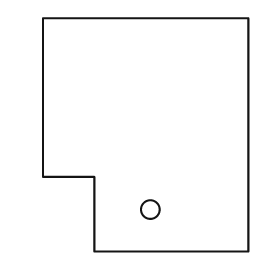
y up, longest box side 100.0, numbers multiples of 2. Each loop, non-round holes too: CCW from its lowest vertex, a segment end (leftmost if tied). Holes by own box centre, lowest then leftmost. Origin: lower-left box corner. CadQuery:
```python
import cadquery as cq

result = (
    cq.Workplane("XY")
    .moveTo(22.0, 0.0)
    .lineTo(88.0, 0.0)
    .lineTo(88.0, 100.0)
    .lineTo(0.0, 100.0)
    .lineTo(0.0, 32.0)
    .lineTo(22.0, 32.0)
    .close()
    .moveTo(46.0, 18.0)
    .circle(4.0)
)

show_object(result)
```